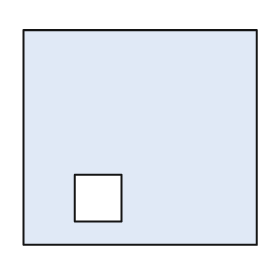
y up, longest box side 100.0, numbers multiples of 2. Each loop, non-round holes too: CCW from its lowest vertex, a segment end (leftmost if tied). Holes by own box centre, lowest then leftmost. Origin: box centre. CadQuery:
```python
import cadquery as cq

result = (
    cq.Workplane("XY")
    .moveTo(-50.0, -46.0)
    .lineTo(50.0, -46.0)
    .lineTo(50.0, 46.0)
    .lineTo(-50.0, 46.0)
    .close()
    .moveTo(-28.0, -36.0)
    .lineTo(-8.0, -36.0)
    .lineTo(-8.0, -16.0)
    .lineTo(-28.0, -16.0)
    .close()
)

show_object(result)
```